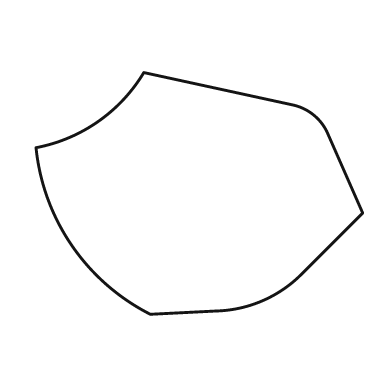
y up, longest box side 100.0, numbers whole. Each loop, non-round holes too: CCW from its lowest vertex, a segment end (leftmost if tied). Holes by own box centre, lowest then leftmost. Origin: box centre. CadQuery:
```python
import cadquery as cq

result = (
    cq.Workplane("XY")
    .moveTo(-15.0, -37.0)
    .lineTo(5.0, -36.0)
    .threePointArc((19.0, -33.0), (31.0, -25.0))
    .lineTo(50.0, -6.0)
    .lineTo(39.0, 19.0)
    .threePointArc((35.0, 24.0), (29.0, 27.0))
    .lineTo(-17.0, 37.0)
    .threePointArc((-31.0, 22.0), (-50.0, 14.0))
    .threePointArc((-39.0, -16.0), (-15.0, -37.0))
    .close()
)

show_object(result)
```